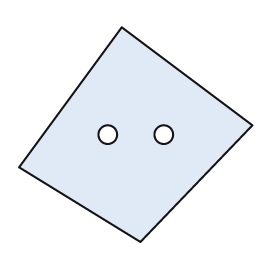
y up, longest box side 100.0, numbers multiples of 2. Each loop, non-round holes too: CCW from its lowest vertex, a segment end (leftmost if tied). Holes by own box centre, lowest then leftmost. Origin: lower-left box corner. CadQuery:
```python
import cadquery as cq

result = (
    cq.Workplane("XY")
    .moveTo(52.0, 0.0)
    .lineTo(100.0, 50.0)
    .lineTo(44.0, 92.0)
    .lineTo(0.0, 32.0)
    .close()
    .moveTo(38.0, 46.0)
    .circle(4.0)
    .moveTo(62.0, 46.0)
    .circle(4.0)
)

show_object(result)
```